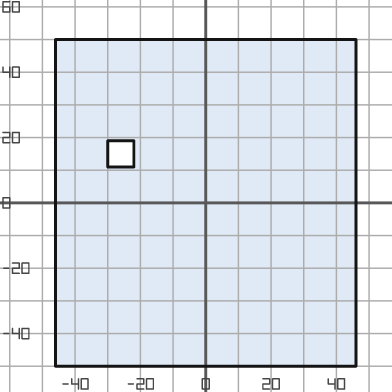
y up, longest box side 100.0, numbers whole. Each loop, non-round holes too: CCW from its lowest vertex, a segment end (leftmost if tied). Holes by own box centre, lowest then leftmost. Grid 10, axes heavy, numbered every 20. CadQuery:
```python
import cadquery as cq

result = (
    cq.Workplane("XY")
    .moveTo(-46.0, -50.0)
    .lineTo(46.0, -50.0)
    .lineTo(46.0, 50.0)
    .lineTo(-46.0, 50.0)
    .close()
    .moveTo(-30.0, 11.0)
    .lineTo(-22.0, 11.0)
    .lineTo(-22.0, 19.0)
    .lineTo(-30.0, 19.0)
    .close()
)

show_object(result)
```